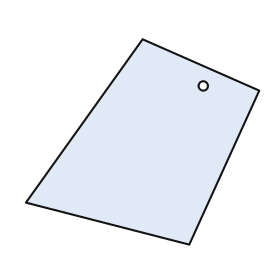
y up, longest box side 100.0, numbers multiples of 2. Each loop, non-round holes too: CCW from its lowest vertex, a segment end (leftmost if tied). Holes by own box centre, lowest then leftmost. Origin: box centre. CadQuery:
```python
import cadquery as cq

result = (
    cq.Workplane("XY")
    .moveTo(20.0, -44.0)
    .lineTo(50.0, 22.0)
    .lineTo(0.0, 44.0)
    .lineTo(-50.0, -26.0)
    .close()
    .moveTo(26.0, 24.0)
    .circle(2.0)
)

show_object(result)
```